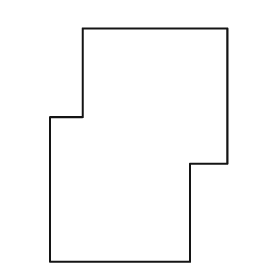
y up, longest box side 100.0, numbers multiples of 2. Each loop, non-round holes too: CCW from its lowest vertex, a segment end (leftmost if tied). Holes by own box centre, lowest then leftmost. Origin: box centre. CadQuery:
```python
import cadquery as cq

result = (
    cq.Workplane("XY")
    .moveTo(-38.0, -50.0)
    .lineTo(22.0, -50.0)
    .lineTo(22.0, -8.0)
    .lineTo(38.0, -8.0)
    .lineTo(38.0, 50.0)
    .lineTo(-24.0, 50.0)
    .lineTo(-24.0, 12.0)
    .lineTo(-38.0, 12.0)
    .close()
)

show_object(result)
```